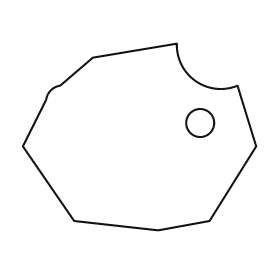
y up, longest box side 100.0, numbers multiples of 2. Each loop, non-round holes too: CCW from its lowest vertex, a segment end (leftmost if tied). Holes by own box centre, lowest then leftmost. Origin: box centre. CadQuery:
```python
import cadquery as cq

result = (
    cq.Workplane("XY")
    .moveTo(8.0, -40.0)
    .lineTo(30.0, -36.0)
    .lineTo(50.0, -4.0)
    .lineTo(42.0, 22.0)
    .threePointArc((24.0, 24.0), (16.0, 40.0))
    .lineTo(-20.0, 34.0)
    .lineTo(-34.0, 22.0)
    .threePointArc((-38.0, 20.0), (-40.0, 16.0))
    .lineTo(-50.0, -4.0)
    .lineTo(-28.0, -36.0)
    .close()
    .moveTo(26.0, 6.0)
    .circle(6.0)
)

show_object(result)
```